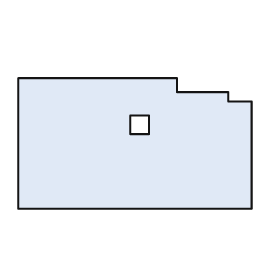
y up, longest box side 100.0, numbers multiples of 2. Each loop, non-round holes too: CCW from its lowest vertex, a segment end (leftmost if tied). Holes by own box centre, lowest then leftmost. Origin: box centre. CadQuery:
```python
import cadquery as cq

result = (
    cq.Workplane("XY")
    .moveTo(-50.0, -28.0)
    .lineTo(50.0, -28.0)
    .lineTo(50.0, 18.0)
    .lineTo(40.0, 18.0)
    .lineTo(40.0, 22.0)
    .lineTo(18.0, 22.0)
    .lineTo(18.0, 28.0)
    .lineTo(-50.0, 28.0)
    .close()
    .moveTo(-2.0, 4.0)
    .lineTo(6.0, 4.0)
    .lineTo(6.0, 12.0)
    .lineTo(-2.0, 12.0)
    .close()
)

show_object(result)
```